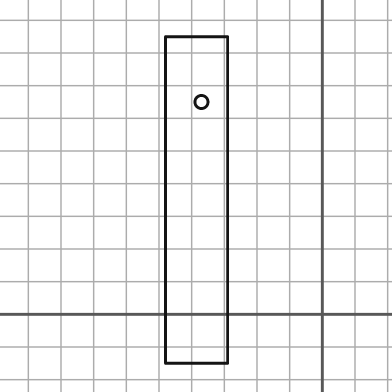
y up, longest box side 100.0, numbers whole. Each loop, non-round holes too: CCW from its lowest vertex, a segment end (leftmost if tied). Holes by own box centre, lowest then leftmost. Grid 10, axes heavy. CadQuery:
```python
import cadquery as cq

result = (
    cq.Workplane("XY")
    .moveTo(-48.0, -15.0)
    .lineTo(-29.0, -15.0)
    .lineTo(-29.0, 85.0)
    .lineTo(-48.0, 85.0)
    .close()
    .moveTo(-37.0, 65.0)
    .circle(2.0)
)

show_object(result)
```